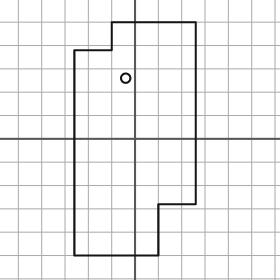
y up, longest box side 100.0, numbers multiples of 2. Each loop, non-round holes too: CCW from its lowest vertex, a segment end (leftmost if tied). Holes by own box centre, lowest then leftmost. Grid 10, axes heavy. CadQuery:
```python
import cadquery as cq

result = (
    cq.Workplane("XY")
    .moveTo(-26.0, -50.0)
    .lineTo(10.0, -50.0)
    .lineTo(10.0, -28.0)
    .lineTo(26.0, -28.0)
    .lineTo(26.0, 50.0)
    .lineTo(-10.0, 50.0)
    .lineTo(-10.0, 38.0)
    .lineTo(-26.0, 38.0)
    .close()
    .moveTo(-4.0, 26.0)
    .circle(2.0)
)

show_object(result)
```